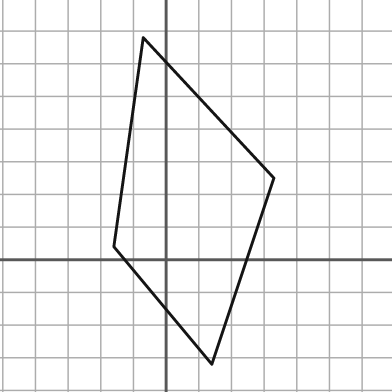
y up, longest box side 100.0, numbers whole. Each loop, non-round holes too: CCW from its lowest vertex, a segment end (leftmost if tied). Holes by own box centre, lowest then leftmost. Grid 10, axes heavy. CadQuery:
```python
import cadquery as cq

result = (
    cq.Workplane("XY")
    .moveTo(14.0, -32.0)
    .lineTo(33.0, 25.0)
    .lineTo(-7.0, 68.0)
    .lineTo(-16.0, 4.0)
    .close()
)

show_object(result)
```